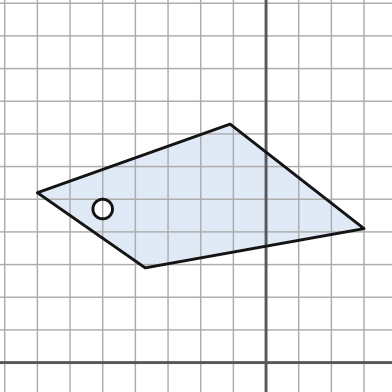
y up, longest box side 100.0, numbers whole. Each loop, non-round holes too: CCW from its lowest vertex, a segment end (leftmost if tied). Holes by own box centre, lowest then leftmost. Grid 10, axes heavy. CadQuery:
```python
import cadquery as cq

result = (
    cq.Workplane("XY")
    .moveTo(-37.0, 29.0)
    .lineTo(30.0, 41.0)
    .lineTo(-11.0, 73.0)
    .lineTo(-70.0, 52.0)
    .close()
    .moveTo(-50.0, 47.0)
    .circle(3.0)
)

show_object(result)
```